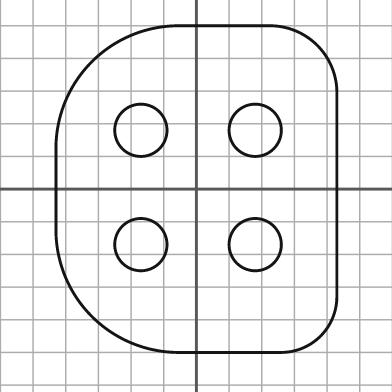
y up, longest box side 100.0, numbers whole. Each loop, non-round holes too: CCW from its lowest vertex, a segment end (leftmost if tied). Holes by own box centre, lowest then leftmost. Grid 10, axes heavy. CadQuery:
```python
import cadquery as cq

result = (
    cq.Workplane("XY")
    .moveTo(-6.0, -50.0)
    .lineTo(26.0, -50.0)
    .threePointArc((38.0, -45.0), (43.0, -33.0))
    .lineTo(43.0, 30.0)
    .threePointArc((37.0, 44.0), (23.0, 50.0))
    .lineTo(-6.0, 50.0)
    .threePointArc((-32.0, 39.0), (-43.0, 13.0))
    .lineTo(-43.0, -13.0)
    .threePointArc((-32.0, -39.0), (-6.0, -50.0))
    .close()
    .moveTo(-17.0, -17.0)
    .circle(8.0)
    .moveTo(18.0, -17.0)
    .circle(8.0)
    .moveTo(-17.0, 18.0)
    .circle(8.0)
    .moveTo(18.0, 18.0)
    .circle(8.0)
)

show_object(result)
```